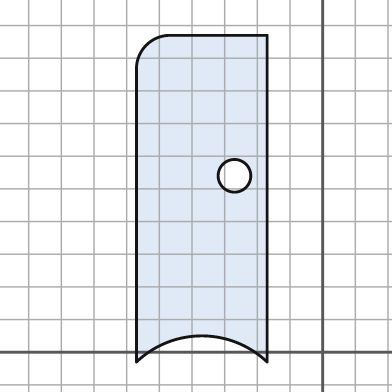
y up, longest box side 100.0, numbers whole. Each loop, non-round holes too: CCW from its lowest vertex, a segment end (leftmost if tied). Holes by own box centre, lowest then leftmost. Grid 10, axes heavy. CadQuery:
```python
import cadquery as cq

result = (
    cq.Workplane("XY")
    .moveTo(-57.0, -3.0)
    .threePointArc((-37.0, 5.0), (-17.0, -3.0))
    .lineTo(-17.0, 97.0)
    .lineTo(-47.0, 97.0)
    .threePointArc((-54.0, 94.0), (-57.0, 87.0))
    .close()
    .moveTo(-27.0, 54.0)
    .circle(5.0)
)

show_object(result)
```